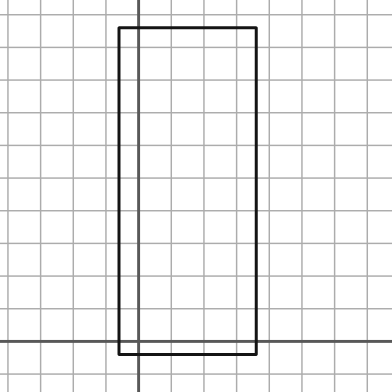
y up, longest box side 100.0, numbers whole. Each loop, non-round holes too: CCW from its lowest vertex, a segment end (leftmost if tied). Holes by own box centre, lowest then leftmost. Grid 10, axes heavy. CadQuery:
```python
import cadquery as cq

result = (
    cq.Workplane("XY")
    .moveTo(-6.0, -4.0)
    .lineTo(36.0, -4.0)
    .lineTo(36.0, 96.0)
    .lineTo(-6.0, 96.0)
    .close()
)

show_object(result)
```